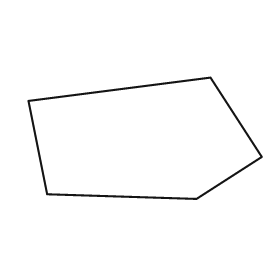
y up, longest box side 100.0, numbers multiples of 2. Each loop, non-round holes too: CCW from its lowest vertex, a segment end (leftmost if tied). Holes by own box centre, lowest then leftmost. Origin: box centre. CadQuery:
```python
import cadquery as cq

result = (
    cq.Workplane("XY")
    .moveTo(22.0, -26.0)
    .lineTo(50.0, -8.0)
    .lineTo(28.0, 26.0)
    .lineTo(-50.0, 16.0)
    .lineTo(-42.0, -24.0)
    .close()
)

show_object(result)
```